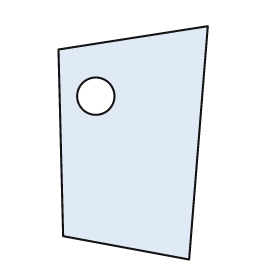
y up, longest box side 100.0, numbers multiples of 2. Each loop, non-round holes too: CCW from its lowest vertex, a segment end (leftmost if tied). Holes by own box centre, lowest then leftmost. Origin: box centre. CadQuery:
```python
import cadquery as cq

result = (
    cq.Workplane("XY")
    .moveTo(24.0, -50.0)
    .lineTo(32.0, 50.0)
    .lineTo(-32.0, 40.0)
    .lineTo(-30.0, -40.0)
    .close()
    .moveTo(-16.0, 20.0)
    .circle(8.0)
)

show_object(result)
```